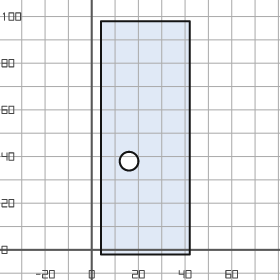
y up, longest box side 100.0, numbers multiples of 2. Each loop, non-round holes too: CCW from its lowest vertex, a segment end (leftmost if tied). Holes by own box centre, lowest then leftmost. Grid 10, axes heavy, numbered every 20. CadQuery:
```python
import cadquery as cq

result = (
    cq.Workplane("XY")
    .moveTo(4.0, -2.0)
    .lineTo(42.0, -2.0)
    .lineTo(42.0, 98.0)
    .lineTo(4.0, 98.0)
    .close()
    .moveTo(16.0, 38.0)
    .circle(4.0)
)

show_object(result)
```